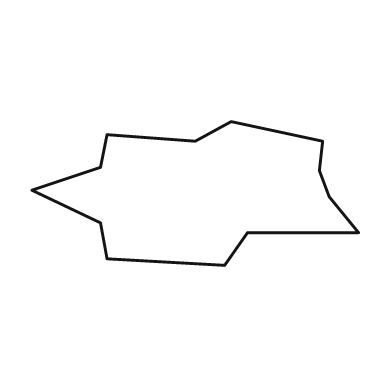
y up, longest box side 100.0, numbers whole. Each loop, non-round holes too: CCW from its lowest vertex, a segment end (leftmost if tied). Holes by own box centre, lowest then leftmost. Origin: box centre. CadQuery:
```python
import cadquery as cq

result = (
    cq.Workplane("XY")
    .moveTo(9.0, -22.0)
    .lineTo(16.0, -12.0)
    .lineTo(50.0, -12.0)
    .lineTo(41.0, -1.0)
    .lineTo(38.0, 7.0)
    .lineTo(39.0, 16.0)
    .lineTo(11.0, 22.0)
    .lineTo(0.0, 16.0)
    .lineTo(-27.0, 18.0)
    .lineTo(-29.0, 8.0)
    .lineTo(-50.0, 1.0)
    .lineTo(-29.0, -9.0)
    .lineTo(-27.0, -20.0)
    .close()
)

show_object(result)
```